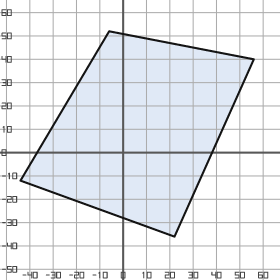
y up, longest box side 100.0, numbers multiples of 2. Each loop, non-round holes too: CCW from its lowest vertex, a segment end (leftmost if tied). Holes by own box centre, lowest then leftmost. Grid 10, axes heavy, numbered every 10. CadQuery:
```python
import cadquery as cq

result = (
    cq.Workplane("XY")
    .moveTo(22.0, -36.0)
    .lineTo(56.0, 40.0)
    .lineTo(-6.0, 52.0)
    .lineTo(-44.0, -12.0)
    .close()
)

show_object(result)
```